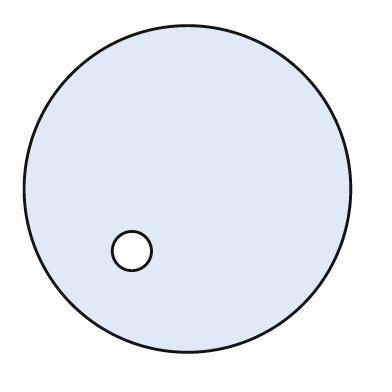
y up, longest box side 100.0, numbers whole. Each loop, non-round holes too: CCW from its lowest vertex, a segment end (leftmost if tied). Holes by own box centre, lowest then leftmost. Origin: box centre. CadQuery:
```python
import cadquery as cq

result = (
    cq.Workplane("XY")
    .moveTo(0.0, 0.0)
    .circle(50.0)
    .moveTo(-17.0, -19.0)
    .circle(6.0)
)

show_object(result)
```